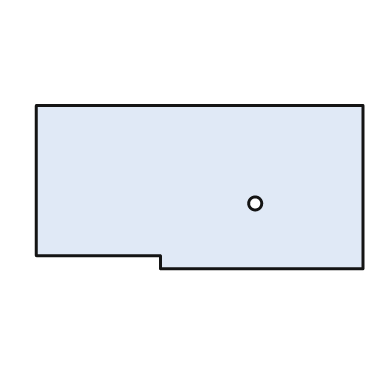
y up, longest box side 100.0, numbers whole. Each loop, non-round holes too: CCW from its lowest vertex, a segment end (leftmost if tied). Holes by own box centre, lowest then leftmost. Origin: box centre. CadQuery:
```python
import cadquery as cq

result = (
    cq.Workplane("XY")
    .moveTo(-12.0, -25.0)
    .lineTo(50.0, -25.0)
    .lineTo(50.0, 25.0)
    .lineTo(-50.0, 25.0)
    .lineTo(-50.0, -21.0)
    .lineTo(-12.0, -21.0)
    .close()
    .moveTo(17.0, -5.0)
    .circle(2.0)
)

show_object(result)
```